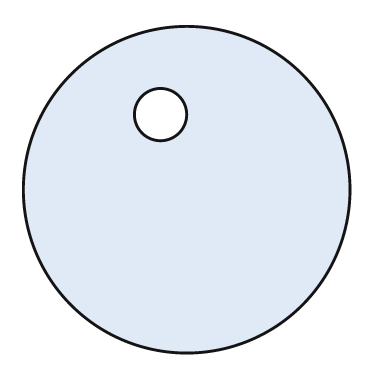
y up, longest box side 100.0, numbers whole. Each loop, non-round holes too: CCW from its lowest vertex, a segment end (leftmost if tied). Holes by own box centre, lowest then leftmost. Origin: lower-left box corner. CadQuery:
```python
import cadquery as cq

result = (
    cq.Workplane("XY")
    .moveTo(50.0, 50.0)
    .circle(50.0)
    .moveTo(42.0, 73.0)
    .circle(8.0)
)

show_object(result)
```